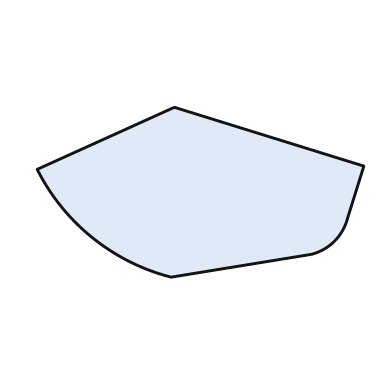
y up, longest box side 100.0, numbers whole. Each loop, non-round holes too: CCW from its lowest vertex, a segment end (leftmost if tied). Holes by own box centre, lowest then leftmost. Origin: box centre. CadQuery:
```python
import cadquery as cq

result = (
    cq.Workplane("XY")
    .moveTo(-9.0, -26.0)
    .lineTo(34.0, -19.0)
    .threePointArc((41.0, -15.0), (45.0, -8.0))
    .lineTo(50.0, 8.0)
    .lineTo(-8.0, 26.0)
    .lineTo(-50.0, 7.0)
    .threePointArc((-33.0, -14.0), (-9.0, -26.0))
    .close()
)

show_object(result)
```